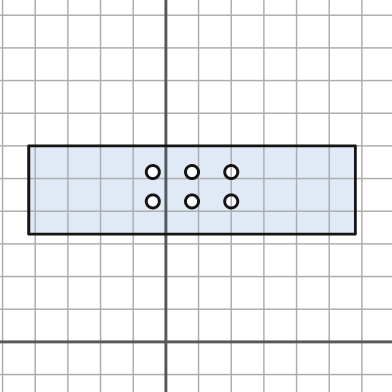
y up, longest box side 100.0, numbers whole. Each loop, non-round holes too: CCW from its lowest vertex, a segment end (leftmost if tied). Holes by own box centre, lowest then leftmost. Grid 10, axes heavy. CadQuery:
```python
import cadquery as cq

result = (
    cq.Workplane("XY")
    .moveTo(-42.0, 33.0)
    .lineTo(58.0, 33.0)
    .lineTo(58.0, 60.0)
    .lineTo(-42.0, 60.0)
    .close()
    .moveTo(-4.0, 43.0)
    .circle(2.0)
    .moveTo(8.0, 43.0)
    .circle(2.0)
    .moveTo(20.0, 43.0)
    .circle(2.0)
    .moveTo(-4.0, 52.0)
    .circle(2.0)
    .moveTo(8.0, 52.0)
    .circle(2.0)
    .moveTo(20.0, 52.0)
    .circle(2.0)
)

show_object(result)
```